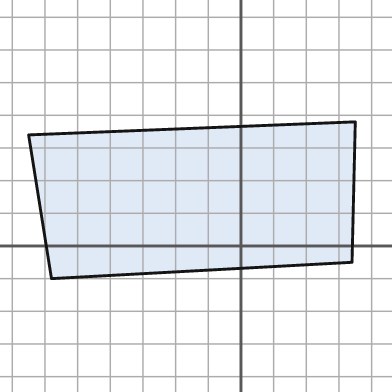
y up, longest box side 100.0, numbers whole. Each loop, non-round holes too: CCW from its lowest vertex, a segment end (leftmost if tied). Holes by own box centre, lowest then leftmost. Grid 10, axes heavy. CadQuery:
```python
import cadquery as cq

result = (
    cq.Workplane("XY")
    .moveTo(-58.0, -10.0)
    .lineTo(34.0, -5.0)
    .lineTo(35.0, 38.0)
    .lineTo(-65.0, 34.0)
    .close()
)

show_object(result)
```